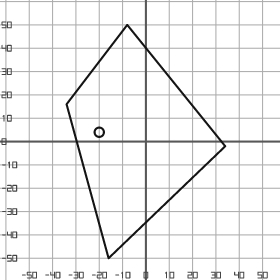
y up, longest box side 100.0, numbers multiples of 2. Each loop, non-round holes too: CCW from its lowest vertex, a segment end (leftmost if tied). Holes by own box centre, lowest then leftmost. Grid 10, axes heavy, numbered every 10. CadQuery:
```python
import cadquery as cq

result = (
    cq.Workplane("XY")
    .moveTo(-16.0, -50.0)
    .lineTo(34.0, -2.0)
    .lineTo(-8.0, 50.0)
    .lineTo(-34.0, 16.0)
    .close()
    .moveTo(-20.0, 4.0)
    .circle(2.0)
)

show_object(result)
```